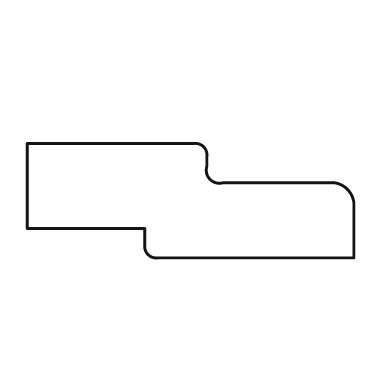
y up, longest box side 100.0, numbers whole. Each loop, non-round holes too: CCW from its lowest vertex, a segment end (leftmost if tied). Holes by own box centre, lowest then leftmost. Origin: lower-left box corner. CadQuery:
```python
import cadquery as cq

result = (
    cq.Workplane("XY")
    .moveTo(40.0, 0.0)
    .lineTo(100.0, 0.0)
    .lineTo(100.0, 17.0)
    .threePointArc((98.0, 21.0), (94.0, 23.0))
    .lineTo(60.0, 23.0)
    .threePointArc((56.0, 24.0), (55.0, 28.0))
    .lineTo(55.0, 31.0)
    .threePointArc((54.0, 34.0), (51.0, 35.0))
    .lineTo(0.0, 35.0)
    .lineTo(0.0, 9.0)
    .lineTo(36.0, 9.0)
    .lineTo(36.0, 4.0)
    .threePointArc((37.0, 1.0), (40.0, 0.0))
    .close()
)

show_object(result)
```